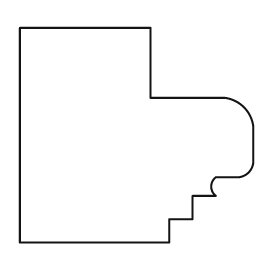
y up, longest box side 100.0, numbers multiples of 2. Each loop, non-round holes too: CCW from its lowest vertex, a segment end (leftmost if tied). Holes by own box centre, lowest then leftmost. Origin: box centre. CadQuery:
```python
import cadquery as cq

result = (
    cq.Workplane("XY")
    .moveTo(-50.0, -46.0)
    .lineTo(14.0, -46.0)
    .lineTo(14.0, -36.0)
    .lineTo(24.0, -36.0)
    .lineTo(24.0, -26.0)
    .lineTo(34.0, -26.0)
    .threePointArc((32.0, -22.0), (34.0, -18.0))
    .lineTo(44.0, -18.0)
    .threePointArc((48.0, -16.0), (50.0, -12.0))
    .lineTo(50.0, 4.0)
    .threePointArc((46.0, 12.0), (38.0, 16.0))
    .lineTo(6.0, 16.0)
    .lineTo(6.0, 46.0)
    .lineTo(-50.0, 46.0)
    .close()
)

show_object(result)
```